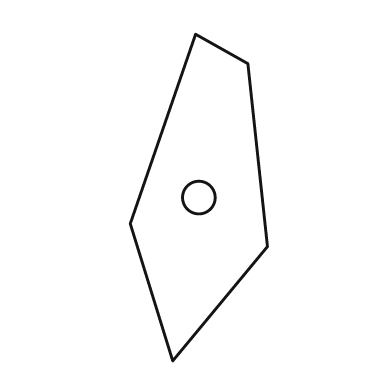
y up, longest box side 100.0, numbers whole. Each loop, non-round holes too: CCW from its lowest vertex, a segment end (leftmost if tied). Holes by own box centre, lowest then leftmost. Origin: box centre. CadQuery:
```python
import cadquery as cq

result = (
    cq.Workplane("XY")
    .moveTo(-8.0, -50.0)
    .lineTo(21.0, -15.0)
    .lineTo(15.0, 41.0)
    .lineTo(-1.0, 50.0)
    .lineTo(-21.0, -8.0)
    .close()
    .moveTo(0.0, 0.0)
    .circle(5.0)
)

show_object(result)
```